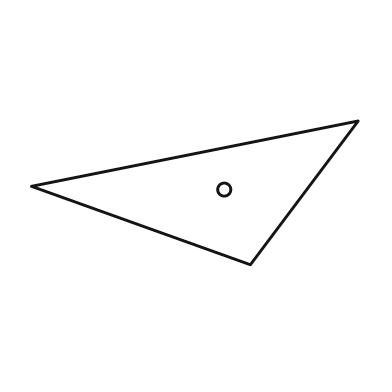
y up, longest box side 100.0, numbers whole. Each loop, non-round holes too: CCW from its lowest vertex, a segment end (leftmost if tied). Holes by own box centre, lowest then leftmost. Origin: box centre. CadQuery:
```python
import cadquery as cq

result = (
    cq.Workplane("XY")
    .moveTo(17.0, -22.0)
    .lineTo(50.0, 22.0)
    .lineTo(-50.0, 2.0)
    .close()
    .moveTo(9.0, 1.0)
    .circle(2.0)
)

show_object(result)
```